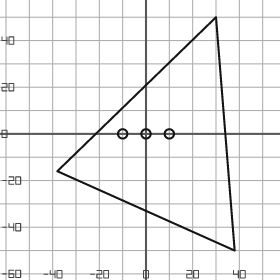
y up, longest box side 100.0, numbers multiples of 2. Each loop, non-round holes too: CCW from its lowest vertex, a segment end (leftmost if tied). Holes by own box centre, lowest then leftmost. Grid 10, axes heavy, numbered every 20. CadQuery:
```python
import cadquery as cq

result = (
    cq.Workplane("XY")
    .moveTo(38.0, -50.0)
    .lineTo(30.0, 50.0)
    .lineTo(-38.0, -16.0)
    .close()
    .moveTo(-10.0, 0.0)
    .circle(2.0)
    .moveTo(0.0, 0.0)
    .circle(2.0)
    .moveTo(10.0, 0.0)
    .circle(2.0)
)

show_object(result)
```